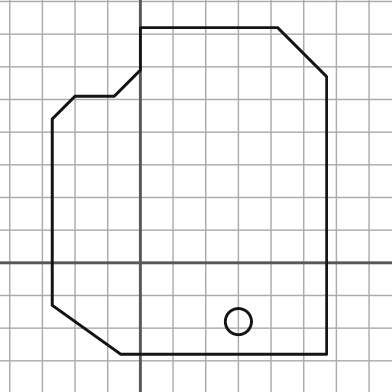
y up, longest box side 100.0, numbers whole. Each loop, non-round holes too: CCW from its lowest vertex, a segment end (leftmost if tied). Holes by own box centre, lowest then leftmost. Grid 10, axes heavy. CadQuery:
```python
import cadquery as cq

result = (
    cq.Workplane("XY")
    .moveTo(-6.0, -28.0)
    .lineTo(57.0, -28.0)
    .lineTo(57.0, 57.0)
    .lineTo(42.0, 72.0)
    .lineTo(0.0, 72.0)
    .lineTo(0.0, 59.0)
    .lineTo(-8.0, 51.0)
    .lineTo(-20.0, 51.0)
    .lineTo(-27.0, 44.0)
    .lineTo(-27.0, -13.0)
    .close()
    .moveTo(30.0, -18.0)
    .circle(4.0)
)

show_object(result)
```